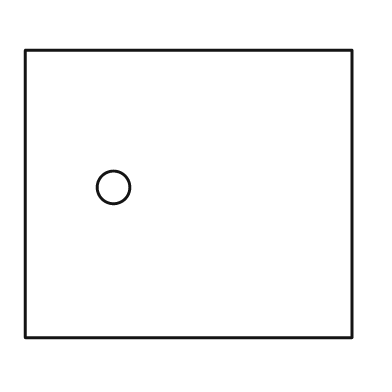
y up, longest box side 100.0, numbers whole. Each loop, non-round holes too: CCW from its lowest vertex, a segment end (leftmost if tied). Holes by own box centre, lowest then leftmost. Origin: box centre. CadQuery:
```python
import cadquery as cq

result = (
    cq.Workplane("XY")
    .moveTo(-50.0, -44.0)
    .lineTo(50.0, -44.0)
    .lineTo(50.0, 44.0)
    .lineTo(-50.0, 44.0)
    .close()
    .moveTo(-23.0, 2.0)
    .circle(5.0)
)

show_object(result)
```